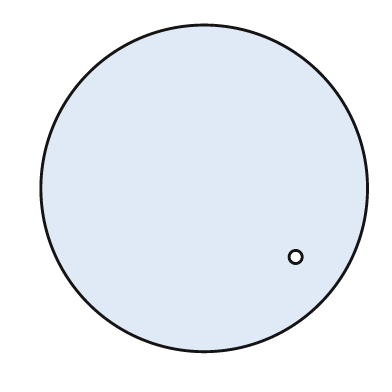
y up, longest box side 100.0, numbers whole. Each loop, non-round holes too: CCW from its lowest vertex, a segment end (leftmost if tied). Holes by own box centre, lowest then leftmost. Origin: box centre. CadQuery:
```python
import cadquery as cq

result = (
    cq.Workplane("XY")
    .moveTo(0.0, 0.0)
    .circle(50.0)
    .moveTo(28.0, -21.0)
    .circle(2.0)
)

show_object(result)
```